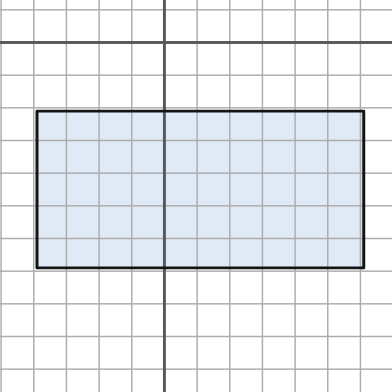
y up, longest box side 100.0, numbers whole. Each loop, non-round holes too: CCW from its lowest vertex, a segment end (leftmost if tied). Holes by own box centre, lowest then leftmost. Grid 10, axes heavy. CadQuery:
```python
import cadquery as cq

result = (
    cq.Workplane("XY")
    .moveTo(-39.0, -69.0)
    .lineTo(61.0, -69.0)
    .lineTo(61.0, -21.0)
    .lineTo(-39.0, -21.0)
    .close()
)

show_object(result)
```